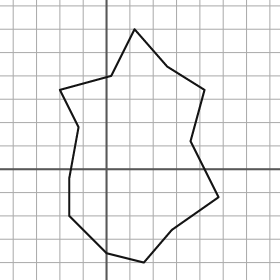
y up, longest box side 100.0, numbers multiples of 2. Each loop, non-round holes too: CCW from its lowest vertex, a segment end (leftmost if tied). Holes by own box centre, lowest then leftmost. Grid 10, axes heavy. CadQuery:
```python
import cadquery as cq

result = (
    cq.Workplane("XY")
    .moveTo(16.0, -40.0)
    .lineTo(28.0, -26.0)
    .lineTo(48.0, -12.0)
    .lineTo(36.0, 12.0)
    .lineTo(42.0, 34.0)
    .lineTo(26.0, 44.0)
    .lineTo(12.0, 60.0)
    .lineTo(2.0, 40.0)
    .lineTo(-20.0, 34.0)
    .lineTo(-12.0, 18.0)
    .lineTo(-16.0, -4.0)
    .lineTo(-16.0, -20.0)
    .lineTo(0.0, -36.0)
    .close()
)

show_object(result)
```